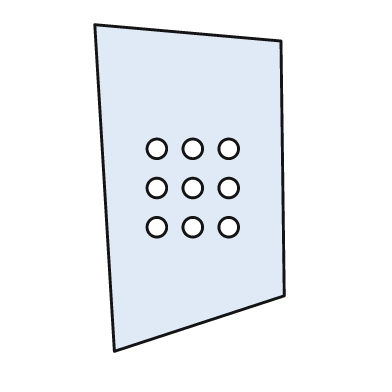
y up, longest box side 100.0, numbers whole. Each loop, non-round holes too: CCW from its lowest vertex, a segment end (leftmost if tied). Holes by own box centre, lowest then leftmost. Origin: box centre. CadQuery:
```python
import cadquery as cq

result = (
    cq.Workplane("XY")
    .moveTo(-23.0, -50.0)
    .lineTo(29.0, -33.0)
    .lineTo(28.0, 45.0)
    .lineTo(-29.0, 50.0)
    .close()
    .moveTo(-10.0, -12.0)
    .circle(3.0)
    .moveTo(1.0, -12.0)
    .circle(3.0)
    .moveTo(12.0, -12.0)
    .circle(3.0)
    .moveTo(-10.0, 0.0)
    .circle(3.0)
    .moveTo(1.0, 0.0)
    .circle(3.0)
    .moveTo(12.0, 0.0)
    .circle(3.0)
    .moveTo(-10.0, 12.0)
    .circle(3.0)
    .moveTo(1.0, 12.0)
    .circle(3.0)
    .moveTo(12.0, 12.0)
    .circle(3.0)
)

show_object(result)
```